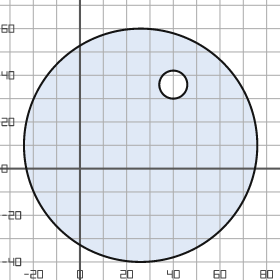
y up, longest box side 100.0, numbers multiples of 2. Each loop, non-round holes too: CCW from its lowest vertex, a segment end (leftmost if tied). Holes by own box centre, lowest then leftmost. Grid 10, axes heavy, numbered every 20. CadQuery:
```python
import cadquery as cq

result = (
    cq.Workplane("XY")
    .moveTo(26.0, 10.0)
    .circle(50.0)
    .moveTo(40.0, 36.0)
    .circle(6.0)
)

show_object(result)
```